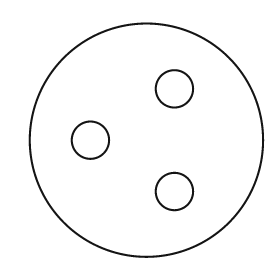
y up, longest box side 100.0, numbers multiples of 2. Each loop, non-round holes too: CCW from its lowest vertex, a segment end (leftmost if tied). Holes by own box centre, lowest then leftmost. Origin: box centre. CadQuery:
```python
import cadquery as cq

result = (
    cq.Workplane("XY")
    .moveTo(0.0, 0.0)
    .circle(50.0)
    .moveTo(12.0, -22.0)
    .circle(8.0)
    .moveTo(-24.0, 0.0)
    .circle(8.0)
    .moveTo(12.0, 22.0)
    .circle(8.0)
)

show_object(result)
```